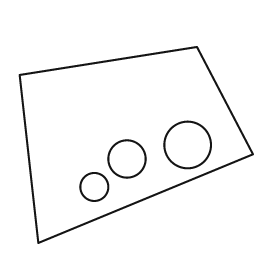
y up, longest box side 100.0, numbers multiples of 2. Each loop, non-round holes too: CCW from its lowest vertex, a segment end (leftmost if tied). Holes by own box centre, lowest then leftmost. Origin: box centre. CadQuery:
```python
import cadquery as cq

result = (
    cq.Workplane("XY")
    .moveTo(-42.0, -42.0)
    .lineTo(50.0, -4.0)
    .lineTo(26.0, 42.0)
    .lineTo(-50.0, 30.0)
    .close()
    .moveTo(-18.0, -18.0)
    .circle(6.0)
    .moveTo(-4.0, -6.0)
    .circle(8.0)
    .moveTo(22.0, 0.0)
    .circle(10.0)
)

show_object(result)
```